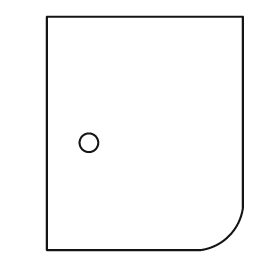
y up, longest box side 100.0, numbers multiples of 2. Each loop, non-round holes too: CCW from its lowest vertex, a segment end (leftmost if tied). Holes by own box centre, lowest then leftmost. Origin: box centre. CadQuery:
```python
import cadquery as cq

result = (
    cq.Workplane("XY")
    .moveTo(-42.0, -50.0)
    .lineTo(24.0, -50.0)
    .threePointArc((36.0, -44.0), (42.0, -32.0))
    .lineTo(42.0, 50.0)
    .lineTo(-42.0, 50.0)
    .close()
    .moveTo(-24.0, -4.0)
    .circle(4.0)
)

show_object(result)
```